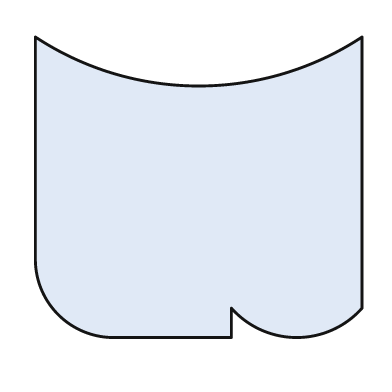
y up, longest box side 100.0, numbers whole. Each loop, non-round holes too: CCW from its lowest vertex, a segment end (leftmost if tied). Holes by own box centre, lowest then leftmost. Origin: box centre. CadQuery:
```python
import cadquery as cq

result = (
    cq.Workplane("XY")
    .moveTo(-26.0, -46.0)
    .lineTo(10.0, -46.0)
    .lineTo(10.0, -37.0)
    .threePointArc((30.0, -46.0), (50.0, -37.0))
    .lineTo(50.0, 46.0)
    .threePointArc((0.0, 31.0), (-50.0, 46.0))
    .lineTo(-50.0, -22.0)
    .threePointArc((-43.0, -39.0), (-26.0, -46.0))
    .close()
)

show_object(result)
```